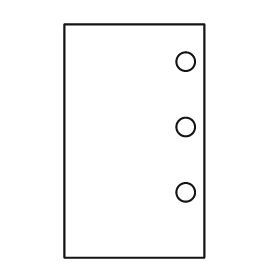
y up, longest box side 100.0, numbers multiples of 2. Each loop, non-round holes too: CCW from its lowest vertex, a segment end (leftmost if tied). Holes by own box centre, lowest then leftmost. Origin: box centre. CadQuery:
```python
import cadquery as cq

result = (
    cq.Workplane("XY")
    .moveTo(-30.0, -50.0)
    .lineTo(30.0, -50.0)
    .lineTo(30.0, 50.0)
    .lineTo(-30.0, 50.0)
    .close()
    .moveTo(22.0, -22.0)
    .circle(4.0)
    .moveTo(22.0, 6.0)
    .circle(4.0)
    .moveTo(22.0, 34.0)
    .circle(4.0)
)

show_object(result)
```